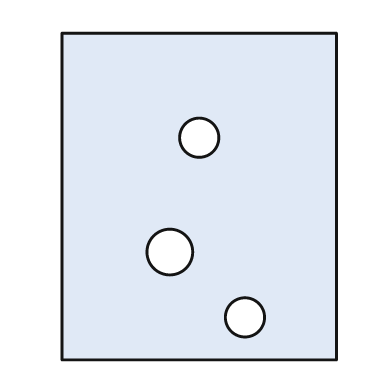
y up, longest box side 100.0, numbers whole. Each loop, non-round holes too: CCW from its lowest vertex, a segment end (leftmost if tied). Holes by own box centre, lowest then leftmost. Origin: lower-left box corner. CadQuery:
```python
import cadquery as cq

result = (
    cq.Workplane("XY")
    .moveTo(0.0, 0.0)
    .lineTo(84.0, 0.0)
    .lineTo(84.0, 100.0)
    .lineTo(0.0, 100.0)
    .close()
    .moveTo(56.0, 13.0)
    .circle(6.0)
    .moveTo(33.0, 33.0)
    .circle(7.0)
    .moveTo(42.0, 68.0)
    .circle(6.0)
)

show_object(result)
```